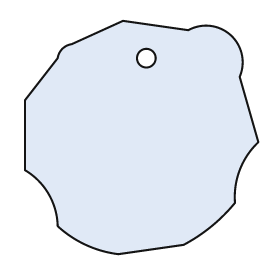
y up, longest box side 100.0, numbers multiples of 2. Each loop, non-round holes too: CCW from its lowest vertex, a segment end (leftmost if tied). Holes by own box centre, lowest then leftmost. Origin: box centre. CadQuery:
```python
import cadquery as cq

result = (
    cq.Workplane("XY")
    .moveTo(-10.0, -50.0)
    .lineTo(18.0, -46.0)
    .threePointArc((30.0, -38.0), (40.0, -28.0))
    .threePointArc((42.0, -14.0), (50.0, -2.0))
    .lineTo(42.0, 26.0)
    .threePointArc((38.0, 44.0), (20.0, 46.0))
    .lineTo(-8.0, 50.0)
    .lineTo(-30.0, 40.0)
    .threePointArc((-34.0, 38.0), (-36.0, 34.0))
    .lineTo(-50.0, 16.0)
    .lineTo(-50.0, -14.0)
    .threePointArc((-40.0, -24.0), (-36.0, -38.0))
    .threePointArc((-24.0, -46.0), (-10.0, -50.0))
    .close()
    .moveTo(2.0, 34.0)
    .circle(4.0)
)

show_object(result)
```